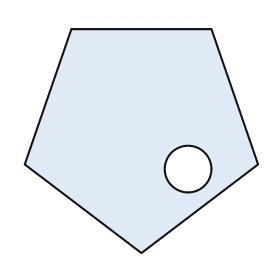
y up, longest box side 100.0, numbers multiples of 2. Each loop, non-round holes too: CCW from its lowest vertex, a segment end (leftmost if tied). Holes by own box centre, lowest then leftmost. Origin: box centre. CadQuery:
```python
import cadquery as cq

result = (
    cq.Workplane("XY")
    .moveTo(0.0, -48.0)
    .lineTo(50.0, -10.0)
    .lineTo(30.0, 48.0)
    .lineTo(-30.0, 48.0)
    .lineTo(-50.0, -10.0)
    .close()
    .moveTo(20.0, -12.0)
    .circle(10.0)
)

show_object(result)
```